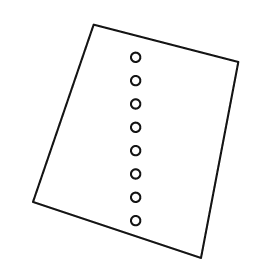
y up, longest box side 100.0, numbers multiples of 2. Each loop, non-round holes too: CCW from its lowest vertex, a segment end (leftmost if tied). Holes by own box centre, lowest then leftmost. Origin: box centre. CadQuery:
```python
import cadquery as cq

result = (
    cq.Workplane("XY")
    .moveTo(28.0, -50.0)
    .lineTo(44.0, 34.0)
    .lineTo(-18.0, 50.0)
    .lineTo(-44.0, -26.0)
    .close()
    .moveTo(0.0, -34.0)
    .circle(2.0)
    .moveTo(0.0, -24.0)
    .circle(2.0)
    .moveTo(0.0, -14.0)
    .circle(2.0)
    .moveTo(0.0, -4.0)
    .circle(2.0)
    .moveTo(0.0, 6.0)
    .circle(2.0)
    .moveTo(0.0, 16.0)
    .circle(2.0)
    .moveTo(0.0, 26.0)
    .circle(2.0)
    .moveTo(0.0, 36.0)
    .circle(2.0)
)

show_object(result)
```